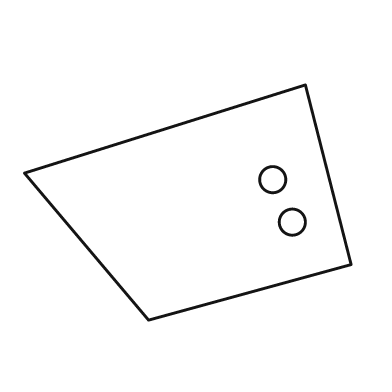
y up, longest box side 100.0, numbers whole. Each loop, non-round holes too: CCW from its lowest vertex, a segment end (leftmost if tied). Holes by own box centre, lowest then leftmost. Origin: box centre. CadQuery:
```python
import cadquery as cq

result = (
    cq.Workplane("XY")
    .moveTo(-12.0, -36.0)
    .lineTo(50.0, -19.0)
    .lineTo(36.0, 36.0)
    .lineTo(-50.0, 9.0)
    .close()
    .moveTo(32.0, -6.0)
    .circle(4.0)
    .moveTo(26.0, 7.0)
    .circle(4.0)
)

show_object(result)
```